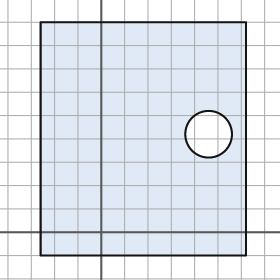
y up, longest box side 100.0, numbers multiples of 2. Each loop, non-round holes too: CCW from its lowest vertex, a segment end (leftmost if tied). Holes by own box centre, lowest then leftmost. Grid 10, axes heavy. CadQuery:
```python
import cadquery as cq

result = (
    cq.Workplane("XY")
    .moveTo(-26.0, -10.0)
    .lineTo(62.0, -10.0)
    .lineTo(62.0, 90.0)
    .lineTo(-26.0, 90.0)
    .close()
    .moveTo(46.0, 42.0)
    .circle(10.0)
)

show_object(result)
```